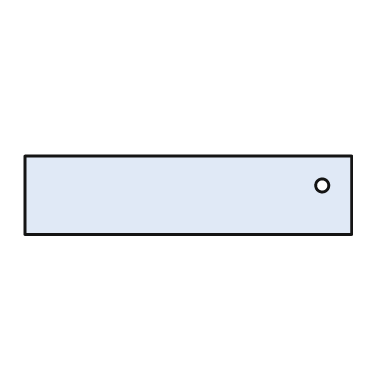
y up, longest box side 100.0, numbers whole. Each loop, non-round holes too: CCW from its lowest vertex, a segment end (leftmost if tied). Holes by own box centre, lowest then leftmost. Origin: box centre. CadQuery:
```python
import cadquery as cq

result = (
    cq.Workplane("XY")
    .moveTo(-50.0, -12.0)
    .lineTo(50.0, -12.0)
    .lineTo(50.0, 12.0)
    .lineTo(-50.0, 12.0)
    .close()
    .moveTo(41.0, 3.0)
    .circle(2.0)
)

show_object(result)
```